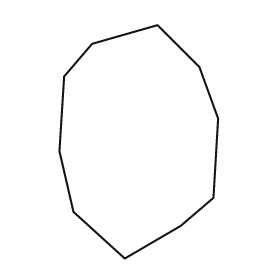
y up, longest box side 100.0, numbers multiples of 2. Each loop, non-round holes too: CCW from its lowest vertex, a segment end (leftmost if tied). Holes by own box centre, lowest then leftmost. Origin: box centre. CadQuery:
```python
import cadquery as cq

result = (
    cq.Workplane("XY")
    .moveTo(-6.0, -50.0)
    .lineTo(18.0, -36.0)
    .lineTo(32.0, -24.0)
    .lineTo(34.0, 10.0)
    .lineTo(26.0, 32.0)
    .lineTo(8.0, 50.0)
    .lineTo(-20.0, 42.0)
    .lineTo(-32.0, 28.0)
    .lineTo(-34.0, -4.0)
    .lineTo(-28.0, -30.0)
    .close()
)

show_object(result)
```